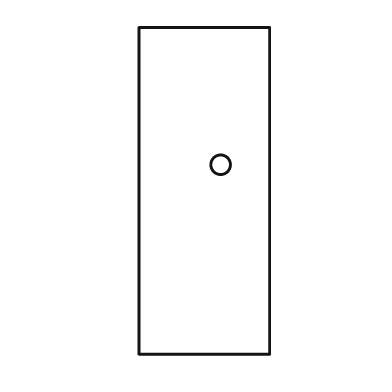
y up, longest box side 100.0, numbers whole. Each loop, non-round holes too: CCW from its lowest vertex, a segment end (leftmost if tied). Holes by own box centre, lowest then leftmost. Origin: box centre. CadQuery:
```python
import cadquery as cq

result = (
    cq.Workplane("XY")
    .moveTo(-20.0, -50.0)
    .lineTo(20.0, -50.0)
    .lineTo(20.0, 50.0)
    .lineTo(-20.0, 50.0)
    .close()
    .moveTo(5.0, 8.0)
    .circle(3.0)
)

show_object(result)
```